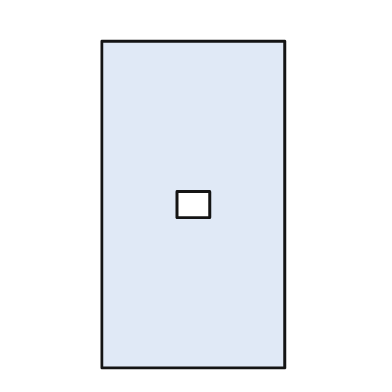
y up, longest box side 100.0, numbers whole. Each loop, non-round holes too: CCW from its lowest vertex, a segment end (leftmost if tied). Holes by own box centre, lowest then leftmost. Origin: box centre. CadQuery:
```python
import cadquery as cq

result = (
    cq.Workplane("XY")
    .moveTo(-28.0, -50.0)
    .lineTo(28.0, -50.0)
    .lineTo(28.0, 50.0)
    .lineTo(-28.0, 50.0)
    .close()
    .moveTo(-5.0, -4.0)
    .lineTo(5.0, -4.0)
    .lineTo(5.0, 4.0)
    .lineTo(-5.0, 4.0)
    .close()
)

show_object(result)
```